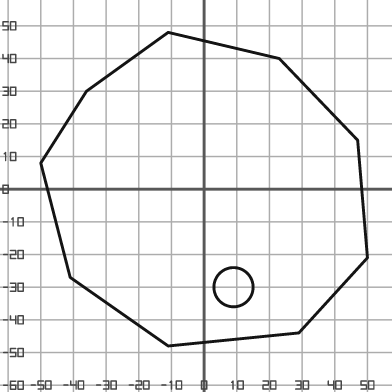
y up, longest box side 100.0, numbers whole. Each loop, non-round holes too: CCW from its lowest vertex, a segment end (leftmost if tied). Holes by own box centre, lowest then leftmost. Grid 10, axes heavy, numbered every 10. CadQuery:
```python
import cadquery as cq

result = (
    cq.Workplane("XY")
    .moveTo(-11.0, -48.0)
    .lineTo(29.0, -44.0)
    .lineTo(50.0, -21.0)
    .lineTo(47.0, 15.0)
    .lineTo(23.0, 40.0)
    .lineTo(-11.0, 48.0)
    .lineTo(-36.0, 30.0)
    .lineTo(-50.0, 8.0)
    .lineTo(-41.0, -27.0)
    .close()
    .moveTo(9.0, -30.0)
    .circle(6.0)
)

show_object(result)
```